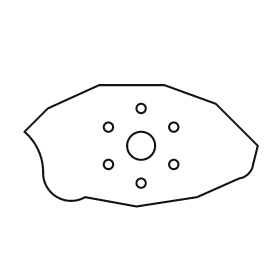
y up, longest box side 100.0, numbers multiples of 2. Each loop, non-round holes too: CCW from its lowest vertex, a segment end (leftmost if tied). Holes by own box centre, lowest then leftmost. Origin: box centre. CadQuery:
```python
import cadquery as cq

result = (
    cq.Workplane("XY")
    .moveTo(-2.0, -26.0)
    .lineTo(24.0, -22.0)
    .lineTo(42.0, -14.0)
    .threePointArc((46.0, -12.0), (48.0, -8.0))
    .lineTo(50.0, 0.0)
    .lineTo(32.0, 18.0)
    .lineTo(10.0, 26.0)
    .lineTo(-18.0, 26.0)
    .lineTo(-40.0, 16.0)
    .lineTo(-50.0, 6.0)
    .threePointArc((-44.0, -2.0), (-42.0, -12.0))
    .threePointArc((-36.0, -22.0), (-24.0, -22.0))
    .close()
    .moveTo(0.0, -16.0)
    .circle(2.0)
    .moveTo(-14.0, -8.0)
    .circle(2.0)
    .moveTo(14.0, -8.0)
    .circle(2.0)
    .moveTo(0.0, 0.0)
    .circle(6.0)
    .moveTo(-14.0, 8.0)
    .circle(2.0)
    .moveTo(14.0, 8.0)
    .circle(2.0)
    .moveTo(0.0, 16.0)
    .circle(2.0)
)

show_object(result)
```